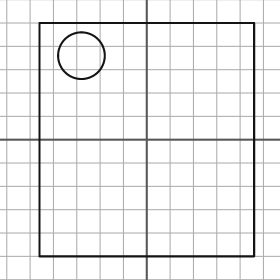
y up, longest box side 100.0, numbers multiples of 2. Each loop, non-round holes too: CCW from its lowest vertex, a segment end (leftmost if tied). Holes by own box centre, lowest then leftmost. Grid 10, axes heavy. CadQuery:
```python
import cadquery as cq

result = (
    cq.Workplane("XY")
    .moveTo(-46.0, -50.0)
    .lineTo(46.0, -50.0)
    .lineTo(46.0, 50.0)
    .lineTo(-46.0, 50.0)
    .close()
    .moveTo(-28.0, 36.0)
    .circle(10.0)
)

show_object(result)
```